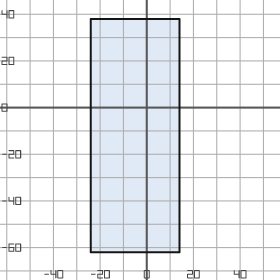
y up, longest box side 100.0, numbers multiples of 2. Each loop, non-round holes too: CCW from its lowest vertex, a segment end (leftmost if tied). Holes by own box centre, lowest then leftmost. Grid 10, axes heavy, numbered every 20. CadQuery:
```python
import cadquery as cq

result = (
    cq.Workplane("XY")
    .moveTo(-24.0, -62.0)
    .lineTo(14.0, -62.0)
    .lineTo(14.0, 38.0)
    .lineTo(-24.0, 38.0)
    .close()
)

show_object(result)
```